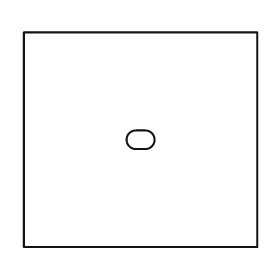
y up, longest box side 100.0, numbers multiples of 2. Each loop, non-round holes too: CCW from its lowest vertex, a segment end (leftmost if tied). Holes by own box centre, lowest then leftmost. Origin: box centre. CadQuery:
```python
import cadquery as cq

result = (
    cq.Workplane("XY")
    .moveTo(-50.0, -46.0)
    .lineTo(50.0, -46.0)
    .lineTo(50.0, 46.0)
    .lineTo(-50.0, 46.0)
    .close()
    .moveTo(-2.0, -4.0)
    .lineTo(2.0, -4.0)
    .threePointArc((6.0, 0.0), (2.0, 4.0))
    .lineTo(-2.0, 4.0)
    .threePointArc((-6.0, 0.0), (-2.0, -4.0))
    .close()
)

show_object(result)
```